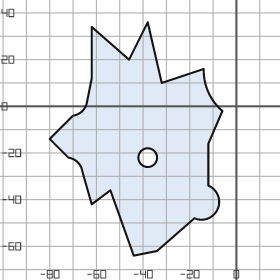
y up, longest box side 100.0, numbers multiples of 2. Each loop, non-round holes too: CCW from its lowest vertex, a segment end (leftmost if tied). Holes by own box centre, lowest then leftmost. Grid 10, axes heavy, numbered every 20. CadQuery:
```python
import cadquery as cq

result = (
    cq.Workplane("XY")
    .moveTo(-44.0, -64.0)
    .lineTo(-34.0, -62.0)
    .lineTo(-18.0, -48.0)
    .threePointArc((-8.0, -44.0), (-12.0, -34.0))
    .lineTo(-12.0, -16.0)
    .lineTo(-6.0, -2.0)
    .threePointArc((-12.0, 6.0), (-14.0, 16.0))
    .lineTo(-32.0, 10.0)
    .lineTo(-38.0, 36.0)
    .lineTo(-46.0, 20.0)
    .lineTo(-62.0, 34.0)
    .lineTo(-62.0, 12.0)
    .lineTo(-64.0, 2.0)
    .threePointArc((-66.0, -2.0), (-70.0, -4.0))
    .lineTo(-80.0, -14.0)
    .lineTo(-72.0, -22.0)
    .threePointArc((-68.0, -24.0), (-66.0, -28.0))
    .lineTo(-62.0, -42.0)
    .lineTo(-54.0, -36.0)
    .close()
    .moveTo(-38.0, -22.0)
    .circle(4.0)
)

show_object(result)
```